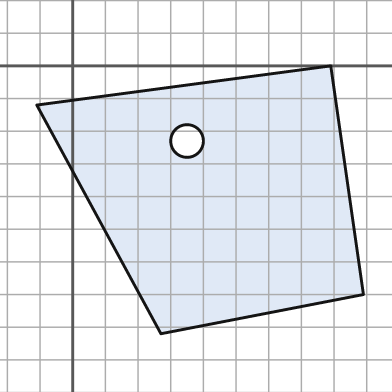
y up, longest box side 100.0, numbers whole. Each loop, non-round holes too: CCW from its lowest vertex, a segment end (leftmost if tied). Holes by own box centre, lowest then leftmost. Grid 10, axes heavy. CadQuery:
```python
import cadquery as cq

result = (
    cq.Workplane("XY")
    .moveTo(27.0, -82.0)
    .lineTo(89.0, -70.0)
    .lineTo(79.0, 0.0)
    .lineTo(-11.0, -12.0)
    .close()
    .moveTo(35.0, -23.0)
    .circle(5.0)
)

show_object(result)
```